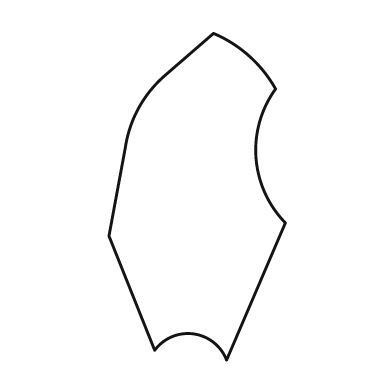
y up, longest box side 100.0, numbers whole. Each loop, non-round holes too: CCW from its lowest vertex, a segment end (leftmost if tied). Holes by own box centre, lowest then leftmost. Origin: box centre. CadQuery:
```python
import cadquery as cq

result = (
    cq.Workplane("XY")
    .moveTo(9.0, -50.0)
    .lineTo(27.0, -8.0)
    .threePointArc((18.0, 12.0), (24.0, 33.0))
    .threePointArc((16.0, 43.0), (5.0, 50.0))
    .lineTo(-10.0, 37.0)
    .threePointArc((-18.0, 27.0), (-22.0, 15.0))
    .lineTo(-27.0, -12.0)
    .lineTo(-13.0, -47.0)
    .threePointArc((-1.0, -42.0), (9.0, -50.0))
    .close()
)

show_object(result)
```